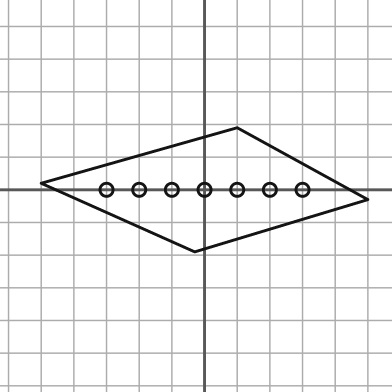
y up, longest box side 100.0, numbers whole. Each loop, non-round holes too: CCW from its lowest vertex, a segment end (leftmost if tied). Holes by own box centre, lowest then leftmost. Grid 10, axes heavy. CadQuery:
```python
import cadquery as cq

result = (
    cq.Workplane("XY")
    .moveTo(-3.0, -19.0)
    .lineTo(50.0, -3.0)
    .lineTo(10.0, 19.0)
    .lineTo(-50.0, 2.0)
    .close()
    .moveTo(-30.0, 0.0)
    .circle(2.0)
    .moveTo(-20.0, 0.0)
    .circle(2.0)
    .moveTo(-10.0, 0.0)
    .circle(2.0)
    .moveTo(0.0, 0.0)
    .circle(2.0)
    .moveTo(10.0, 0.0)
    .circle(2.0)
    .moveTo(20.0, 0.0)
    .circle(2.0)
    .moveTo(30.0, 0.0)
    .circle(2.0)
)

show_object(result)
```